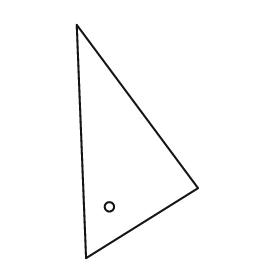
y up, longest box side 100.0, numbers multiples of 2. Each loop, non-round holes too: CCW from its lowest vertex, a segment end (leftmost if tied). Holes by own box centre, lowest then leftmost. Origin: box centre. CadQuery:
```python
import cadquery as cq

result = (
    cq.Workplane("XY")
    .moveTo(-22.0, -50.0)
    .lineTo(26.0, -20.0)
    .lineTo(-26.0, 50.0)
    .close()
    .moveTo(-12.0, -28.0)
    .circle(2.0)
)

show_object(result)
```